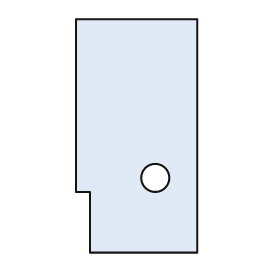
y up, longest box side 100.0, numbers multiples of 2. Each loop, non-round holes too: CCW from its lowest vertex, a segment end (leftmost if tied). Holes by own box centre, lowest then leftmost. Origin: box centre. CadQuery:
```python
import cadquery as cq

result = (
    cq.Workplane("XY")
    .moveTo(-20.0, -50.0)
    .lineTo(26.0, -50.0)
    .lineTo(26.0, 50.0)
    .lineTo(-26.0, 50.0)
    .lineTo(-26.0, -24.0)
    .lineTo(-20.0, -24.0)
    .close()
    .moveTo(8.0, -18.0)
    .circle(6.0)
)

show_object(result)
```